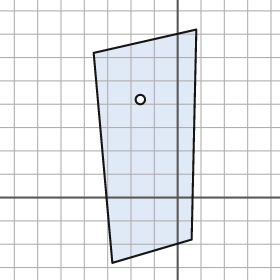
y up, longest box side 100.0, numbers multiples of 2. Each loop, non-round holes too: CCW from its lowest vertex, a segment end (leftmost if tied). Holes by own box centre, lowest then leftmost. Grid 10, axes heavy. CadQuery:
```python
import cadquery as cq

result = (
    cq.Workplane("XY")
    .moveTo(-28.0, -28.0)
    .lineTo(6.0, -18.0)
    .lineTo(8.0, 72.0)
    .lineTo(-36.0, 62.0)
    .close()
    .moveTo(-16.0, 42.0)
    .circle(2.0)
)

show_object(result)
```